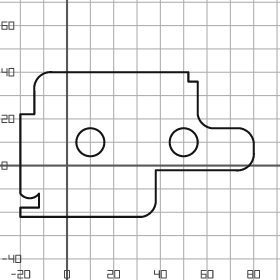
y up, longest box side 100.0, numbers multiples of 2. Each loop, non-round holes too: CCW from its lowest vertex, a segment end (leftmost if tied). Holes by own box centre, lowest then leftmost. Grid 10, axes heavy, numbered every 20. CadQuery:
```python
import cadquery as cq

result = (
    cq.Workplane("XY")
    .moveTo(-20.0, -22.0)
    .lineTo(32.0, -22.0)
    .threePointArc((36.0, -20.0), (38.0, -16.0))
    .lineTo(38.0, -2.0)
    .lineTo(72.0, -2.0)
    .threePointArc((78.0, 0.0), (80.0, 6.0))
    .lineTo(80.0, 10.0)
    .threePointArc((78.0, 14.0), (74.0, 16.0))
    .lineTo(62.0, 16.0)
    .threePointArc((58.0, 18.0), (56.0, 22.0))
    .lineTo(56.0, 36.0)
    .lineTo(52.0, 36.0)
    .lineTo(52.0, 40.0)
    .lineTo(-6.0, 40.0)
    .threePointArc((-12.0, 38.0), (-14.0, 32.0))
    .lineTo(-14.0, 22.0)
    .lineTo(-20.0, 22.0)
    .lineTo(-20.0, -12.0)
    .threePointArc((-16.0, -14.0), (-12.0, -12.0))
    .lineTo(-12.0, -18.0)
    .lineTo(-20.0, -18.0)
    .close()
    .moveTo(10.0, 10.0)
    .circle(6.0)
    .moveTo(50.0, 10.0)
    .circle(6.0)
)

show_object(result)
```